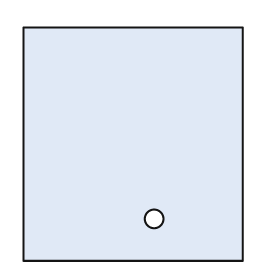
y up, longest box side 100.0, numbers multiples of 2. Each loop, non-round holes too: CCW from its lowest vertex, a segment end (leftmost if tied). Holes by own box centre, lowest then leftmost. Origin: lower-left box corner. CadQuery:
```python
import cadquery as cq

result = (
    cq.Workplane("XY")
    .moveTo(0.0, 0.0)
    .lineTo(94.0, 0.0)
    .lineTo(94.0, 100.0)
    .lineTo(0.0, 100.0)
    .close()
    .moveTo(56.0, 18.0)
    .circle(4.0)
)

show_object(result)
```